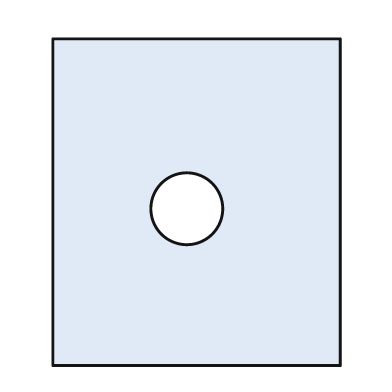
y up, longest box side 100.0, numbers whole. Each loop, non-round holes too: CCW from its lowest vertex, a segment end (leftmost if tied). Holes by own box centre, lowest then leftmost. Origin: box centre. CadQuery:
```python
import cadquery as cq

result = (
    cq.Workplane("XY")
    .moveTo(-44.0, -50.0)
    .lineTo(44.0, -50.0)
    .lineTo(44.0, 50.0)
    .lineTo(-44.0, 50.0)
    .close()
    .moveTo(-3.0, -2.0)
    .circle(11.0)
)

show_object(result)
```